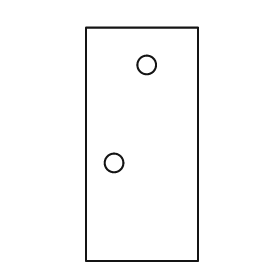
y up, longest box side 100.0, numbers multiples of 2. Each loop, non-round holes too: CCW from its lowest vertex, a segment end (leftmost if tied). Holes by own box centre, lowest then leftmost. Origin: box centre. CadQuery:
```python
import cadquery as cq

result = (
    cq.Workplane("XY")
    .moveTo(-24.0, -50.0)
    .lineTo(24.0, -50.0)
    .lineTo(24.0, 50.0)
    .lineTo(-24.0, 50.0)
    .close()
    .moveTo(-12.0, -8.0)
    .circle(4.0)
    .moveTo(2.0, 34.0)
    .circle(4.0)
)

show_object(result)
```